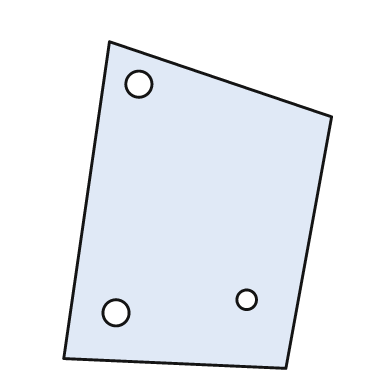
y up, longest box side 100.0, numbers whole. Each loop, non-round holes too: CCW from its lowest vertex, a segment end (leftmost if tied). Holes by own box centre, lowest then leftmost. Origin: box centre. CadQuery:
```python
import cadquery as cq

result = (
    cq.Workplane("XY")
    .moveTo(27.0, -50.0)
    .lineTo(41.0, 27.0)
    .lineTo(-27.0, 50.0)
    .lineTo(-41.0, -47.0)
    .close()
    .moveTo(-25.0, -33.0)
    .circle(4.0)
    .moveTo(15.0, -29.0)
    .circle(3.0)
    .moveTo(-18.0, 37.0)
    .circle(4.0)
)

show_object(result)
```